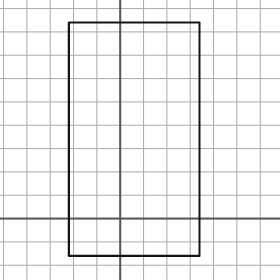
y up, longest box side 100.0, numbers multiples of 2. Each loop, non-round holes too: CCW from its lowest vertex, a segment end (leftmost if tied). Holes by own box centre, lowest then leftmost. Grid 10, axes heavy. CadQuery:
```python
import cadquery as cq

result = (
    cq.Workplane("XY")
    .moveTo(-22.0, -16.0)
    .lineTo(34.0, -16.0)
    .lineTo(34.0, 84.0)
    .lineTo(-22.0, 84.0)
    .close()
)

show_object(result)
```